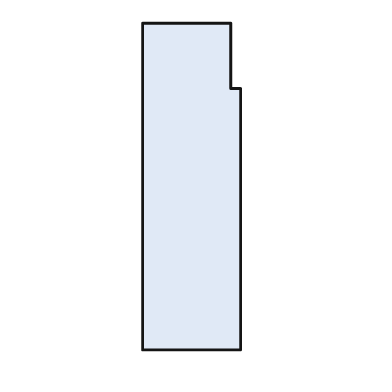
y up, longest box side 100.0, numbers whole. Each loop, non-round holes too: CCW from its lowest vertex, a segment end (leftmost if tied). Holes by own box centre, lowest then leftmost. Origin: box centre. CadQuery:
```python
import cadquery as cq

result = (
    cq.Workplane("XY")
    .moveTo(-15.0, -50.0)
    .lineTo(15.0, -50.0)
    .lineTo(15.0, 30.0)
    .lineTo(12.0, 30.0)
    .lineTo(12.0, 50.0)
    .lineTo(-15.0, 50.0)
    .close()
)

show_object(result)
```